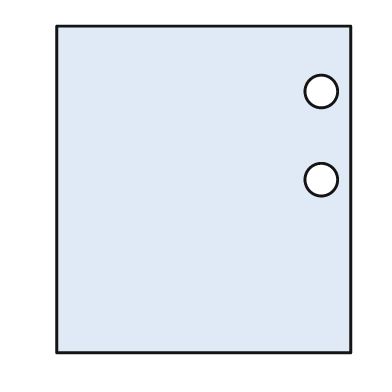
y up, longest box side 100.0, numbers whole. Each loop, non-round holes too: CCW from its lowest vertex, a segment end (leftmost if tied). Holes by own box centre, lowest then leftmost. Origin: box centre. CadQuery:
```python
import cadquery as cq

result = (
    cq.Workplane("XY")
    .moveTo(-45.0, -50.0)
    .lineTo(45.0, -50.0)
    .lineTo(45.0, 50.0)
    .lineTo(-45.0, 50.0)
    .close()
    .moveTo(36.0, 3.0)
    .circle(5.0)
    .moveTo(36.0, 30.0)
    .circle(5.0)
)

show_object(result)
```